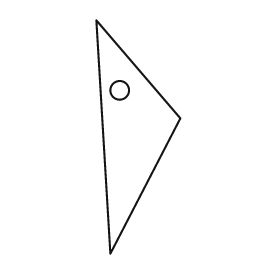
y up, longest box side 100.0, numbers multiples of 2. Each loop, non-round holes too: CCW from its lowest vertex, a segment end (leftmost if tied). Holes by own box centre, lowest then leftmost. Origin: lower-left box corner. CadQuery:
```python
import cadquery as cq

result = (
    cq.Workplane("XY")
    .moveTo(6.0, 0.0)
    .lineTo(36.0, 58.0)
    .lineTo(0.0, 100.0)
    .close()
    .moveTo(10.0, 70.0)
    .circle(4.0)
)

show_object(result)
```